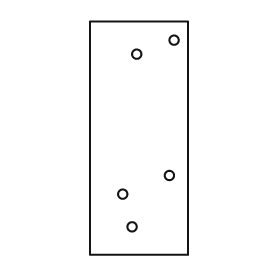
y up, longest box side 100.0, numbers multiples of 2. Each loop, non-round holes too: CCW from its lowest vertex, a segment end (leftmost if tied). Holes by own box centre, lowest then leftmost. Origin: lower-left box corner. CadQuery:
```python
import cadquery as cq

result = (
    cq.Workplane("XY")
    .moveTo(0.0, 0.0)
    .lineTo(42.0, 0.0)
    .lineTo(42.0, 100.0)
    .lineTo(0.0, 100.0)
    .close()
    .moveTo(18.0, 12.0)
    .circle(2.0)
    .moveTo(14.0, 26.0)
    .circle(2.0)
    .moveTo(34.0, 34.0)
    .circle(2.0)
    .moveTo(20.0, 86.0)
    .circle(2.0)
    .moveTo(36.0, 92.0)
    .circle(2.0)
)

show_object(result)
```